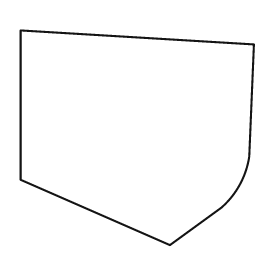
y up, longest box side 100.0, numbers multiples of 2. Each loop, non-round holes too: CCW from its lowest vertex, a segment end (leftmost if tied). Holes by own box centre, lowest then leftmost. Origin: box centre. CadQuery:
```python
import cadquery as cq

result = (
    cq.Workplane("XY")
    .moveTo(14.0, -46.0)
    .lineTo(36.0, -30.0)
    .threePointArc((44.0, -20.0), (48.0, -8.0))
    .lineTo(50.0, 40.0)
    .lineTo(-50.0, 46.0)
    .lineTo(-50.0, -18.0)
    .close()
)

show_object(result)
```